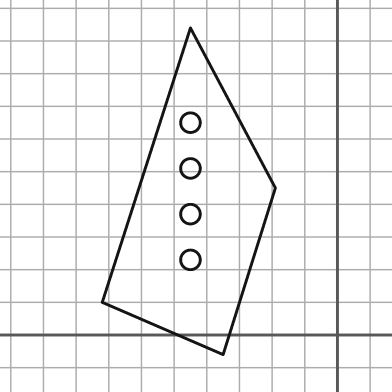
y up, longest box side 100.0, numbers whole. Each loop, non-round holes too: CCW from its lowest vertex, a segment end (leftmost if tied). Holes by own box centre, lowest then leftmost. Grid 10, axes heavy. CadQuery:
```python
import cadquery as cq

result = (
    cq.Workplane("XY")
    .moveTo(-35.0, -6.0)
    .lineTo(-19.0, 45.0)
    .lineTo(-45.0, 94.0)
    .lineTo(-72.0, 10.0)
    .close()
    .moveTo(-45.0, 23.0)
    .circle(3.0)
    .moveTo(-45.0, 37.0)
    .circle(3.0)
    .moveTo(-45.0, 51.0)
    .circle(3.0)
    .moveTo(-45.0, 65.0)
    .circle(3.0)
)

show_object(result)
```